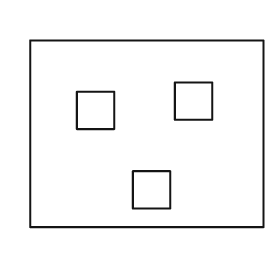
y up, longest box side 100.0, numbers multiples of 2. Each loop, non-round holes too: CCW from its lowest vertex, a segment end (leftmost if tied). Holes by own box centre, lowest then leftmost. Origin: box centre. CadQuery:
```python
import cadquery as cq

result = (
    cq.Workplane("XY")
    .moveTo(-50.0, -40.0)
    .lineTo(50.0, -40.0)
    .lineTo(50.0, 40.0)
    .lineTo(-50.0, 40.0)
    .close()
    .moveTo(-6.0, -32.0)
    .lineTo(10.0, -32.0)
    .lineTo(10.0, -16.0)
    .lineTo(-6.0, -16.0)
    .close()
    .moveTo(-30.0, 2.0)
    .lineTo(-14.0, 2.0)
    .lineTo(-14.0, 18.0)
    .lineTo(-30.0, 18.0)
    .close()
    .moveTo(12.0, 6.0)
    .lineTo(28.0, 6.0)
    .lineTo(28.0, 22.0)
    .lineTo(12.0, 22.0)
    .close()
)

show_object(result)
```